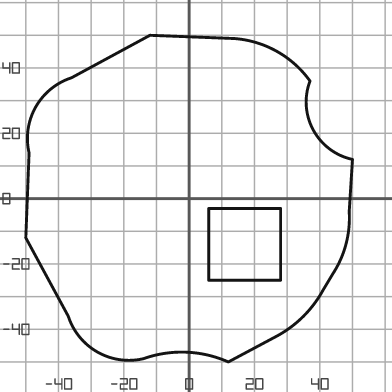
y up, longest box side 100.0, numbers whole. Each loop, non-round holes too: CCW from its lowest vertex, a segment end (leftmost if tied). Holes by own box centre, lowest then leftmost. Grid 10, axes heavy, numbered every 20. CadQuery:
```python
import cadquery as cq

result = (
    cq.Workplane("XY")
    .moveTo(12.0, -50.0)
    .lineTo(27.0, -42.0)
    .threePointArc((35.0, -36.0), (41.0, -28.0))
    .lineTo(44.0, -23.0)
    .threePointArc((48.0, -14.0), (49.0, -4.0))
    .lineTo(50.0, 12.0)
    .threePointArc((38.0, 21.0), (37.0, 36.0))
    .threePointArc((27.0, 45.0), (14.0, 49.0))
    .lineTo(-12.0, 50.0)
    .lineTo(-36.0, 37.0)
    .threePointArc((-47.0, 28.0), (-49.0, 14.0))
    .lineTo(-50.0, -12.0)
    .lineTo(-37.0, -36.0)
    .threePointArc((-28.0, -47.0), (-14.0, -49.0))
    .threePointArc((-1.0, -47.0), (12.0, -50.0))
    .close()
    .moveTo(6.0, -25.0)
    .lineTo(28.0, -25.0)
    .lineTo(28.0, -3.0)
    .lineTo(6.0, -3.0)
    .close()
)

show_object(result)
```